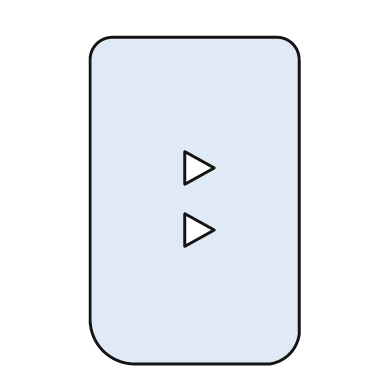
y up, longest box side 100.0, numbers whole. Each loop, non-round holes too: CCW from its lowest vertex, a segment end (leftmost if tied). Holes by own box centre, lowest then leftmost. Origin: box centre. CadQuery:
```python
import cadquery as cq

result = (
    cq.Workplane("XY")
    .moveTo(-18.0, -50.0)
    .lineTo(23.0, -50.0)
    .threePointArc((29.0, -47.0), (32.0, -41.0))
    .lineTo(32.0, 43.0)
    .threePointArc((30.0, 48.0), (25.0, 50.0))
    .lineTo(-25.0, 50.0)
    .threePointArc((-30.0, 48.0), (-32.0, 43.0))
    .lineTo(-32.0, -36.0)
    .threePointArc((-28.0, -46.0), (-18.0, -50.0))
    .close()
    .moveTo(-3.0, -14.0)
    .lineTo(6.0, -9.0)
    .lineTo(-3.0, -4.0)
    .close()
    .moveTo(-3.0, 5.0)
    .lineTo(6.0, 10.0)
    .lineTo(-3.0, 15.0)
    .close()
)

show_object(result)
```